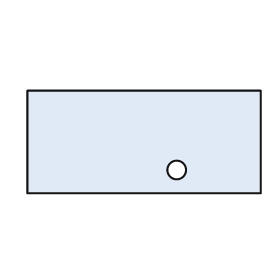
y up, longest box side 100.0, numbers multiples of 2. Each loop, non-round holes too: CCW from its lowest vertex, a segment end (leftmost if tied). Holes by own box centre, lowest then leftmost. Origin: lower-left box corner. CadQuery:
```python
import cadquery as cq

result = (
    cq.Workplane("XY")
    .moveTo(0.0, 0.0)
    .lineTo(100.0, 0.0)
    .lineTo(100.0, 44.0)
    .lineTo(0.0, 44.0)
    .close()
    .moveTo(64.0, 10.0)
    .circle(4.0)
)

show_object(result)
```